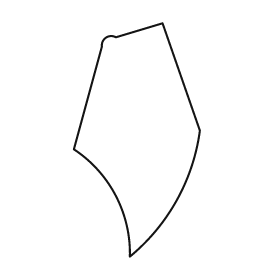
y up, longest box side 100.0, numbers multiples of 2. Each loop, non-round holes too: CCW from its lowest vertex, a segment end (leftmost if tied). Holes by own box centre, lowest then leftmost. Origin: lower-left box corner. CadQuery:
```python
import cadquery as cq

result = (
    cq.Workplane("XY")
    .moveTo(24.0, 0.0)
    .threePointArc((44.0, 24.0), (54.0, 54.0))
    .lineTo(38.0, 100.0)
    .lineTo(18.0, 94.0)
    .threePointArc((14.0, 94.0), (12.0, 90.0))
    .lineTo(0.0, 46.0)
    .threePointArc((18.0, 26.0), (24.0, 0.0))
    .close()
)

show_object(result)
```